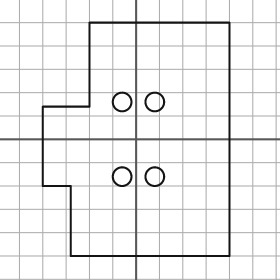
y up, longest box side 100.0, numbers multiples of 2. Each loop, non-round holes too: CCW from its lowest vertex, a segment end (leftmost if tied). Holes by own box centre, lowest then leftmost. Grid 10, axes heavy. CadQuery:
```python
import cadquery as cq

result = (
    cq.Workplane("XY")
    .moveTo(-28.0, -50.0)
    .lineTo(40.0, -50.0)
    .lineTo(40.0, 50.0)
    .lineTo(-20.0, 50.0)
    .lineTo(-20.0, 14.0)
    .lineTo(-40.0, 14.0)
    .lineTo(-40.0, -20.0)
    .lineTo(-28.0, -20.0)
    .close()
    .moveTo(-6.0, -16.0)
    .circle(4.0)
    .moveTo(8.0, -16.0)
    .circle(4.0)
    .moveTo(-6.0, 16.0)
    .circle(4.0)
    .moveTo(8.0, 16.0)
    .circle(4.0)
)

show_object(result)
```